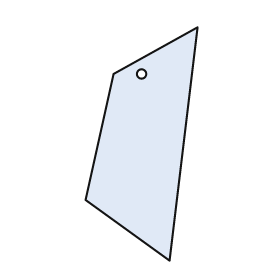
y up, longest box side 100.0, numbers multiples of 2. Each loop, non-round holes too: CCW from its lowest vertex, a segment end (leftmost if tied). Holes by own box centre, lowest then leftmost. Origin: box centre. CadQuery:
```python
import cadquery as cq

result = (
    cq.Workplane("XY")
    .moveTo(12.0, -50.0)
    .lineTo(24.0, 50.0)
    .lineTo(-12.0, 30.0)
    .lineTo(-24.0, -24.0)
    .close()
    .moveTo(0.0, 30.0)
    .circle(2.0)
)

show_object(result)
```